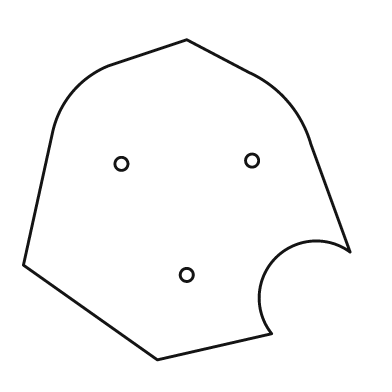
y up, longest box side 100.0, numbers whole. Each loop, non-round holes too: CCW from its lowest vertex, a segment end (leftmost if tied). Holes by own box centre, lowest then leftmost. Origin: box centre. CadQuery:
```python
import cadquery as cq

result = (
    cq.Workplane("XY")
    .moveTo(-9.0, -49.0)
    .lineTo(26.0, -41.0)
    .threePointArc((27.0, -18.0), (50.0, -16.0))
    .lineTo(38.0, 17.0)
    .threePointArc((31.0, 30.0), (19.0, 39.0))
    .lineTo(0.0, 49.0)
    .lineTo(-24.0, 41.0)
    .threePointArc((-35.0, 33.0), (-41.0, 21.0))
    .lineTo(-50.0, -20.0)
    .close()
    .moveTo(0.0, -23.0)
    .circle(2.0)
    .moveTo(-20.0, 11.0)
    .circle(2.0)
    .moveTo(20.0, 12.0)
    .circle(2.0)
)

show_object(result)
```